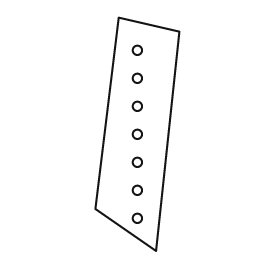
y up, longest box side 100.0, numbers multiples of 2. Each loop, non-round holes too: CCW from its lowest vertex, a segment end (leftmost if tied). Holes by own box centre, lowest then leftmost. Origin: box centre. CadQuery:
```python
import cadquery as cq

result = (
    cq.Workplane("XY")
    .moveTo(8.0, -50.0)
    .lineTo(18.0, 44.0)
    .lineTo(-8.0, 50.0)
    .lineTo(-18.0, -32.0)
    .close()
    .moveTo(0.0, -36.0)
    .circle(2.0)
    .moveTo(0.0, -24.0)
    .circle(2.0)
    .moveTo(0.0, -12.0)
    .circle(2.0)
    .moveTo(0.0, 0.0)
    .circle(2.0)
    .moveTo(0.0, 12.0)
    .circle(2.0)
    .moveTo(0.0, 24.0)
    .circle(2.0)
    .moveTo(0.0, 36.0)
    .circle(2.0)
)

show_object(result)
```